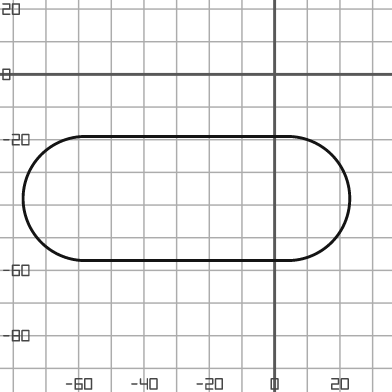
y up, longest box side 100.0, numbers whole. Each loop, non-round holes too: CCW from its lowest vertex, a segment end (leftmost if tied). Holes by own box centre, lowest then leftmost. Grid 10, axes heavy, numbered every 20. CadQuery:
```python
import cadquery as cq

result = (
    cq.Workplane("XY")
    .moveTo(-58.0, -57.0)
    .lineTo(4.0, -57.0)
    .threePointArc((23.0, -38.0), (4.0, -19.0))
    .lineTo(-58.0, -19.0)
    .threePointArc((-77.0, -38.0), (-58.0, -57.0))
    .close()
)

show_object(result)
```